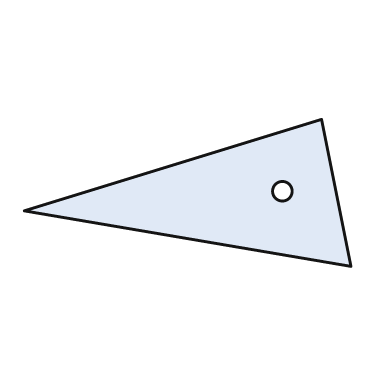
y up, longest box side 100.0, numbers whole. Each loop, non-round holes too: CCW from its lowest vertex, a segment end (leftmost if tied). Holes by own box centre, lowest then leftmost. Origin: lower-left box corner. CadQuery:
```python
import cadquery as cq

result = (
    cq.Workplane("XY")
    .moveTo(100.0, 0.0)
    .lineTo(91.0, 45.0)
    .lineTo(0.0, 17.0)
    .close()
    .moveTo(79.0, 23.0)
    .circle(3.0)
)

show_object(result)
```